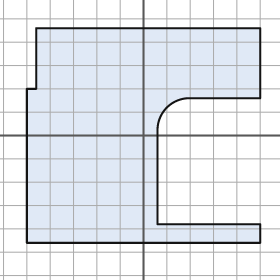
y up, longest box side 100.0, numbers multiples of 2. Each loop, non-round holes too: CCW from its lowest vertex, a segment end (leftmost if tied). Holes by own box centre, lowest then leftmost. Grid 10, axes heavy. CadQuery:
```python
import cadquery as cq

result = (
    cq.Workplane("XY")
    .moveTo(-50.0, -46.0)
    .lineTo(50.0, -46.0)
    .lineTo(50.0, -38.0)
    .lineTo(6.0, -38.0)
    .lineTo(6.0, 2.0)
    .threePointArc((10.0, 12.0), (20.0, 16.0))
    .lineTo(50.0, 16.0)
    .lineTo(50.0, 46.0)
    .lineTo(-46.0, 46.0)
    .lineTo(-46.0, 20.0)
    .lineTo(-50.0, 20.0)
    .close()
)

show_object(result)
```